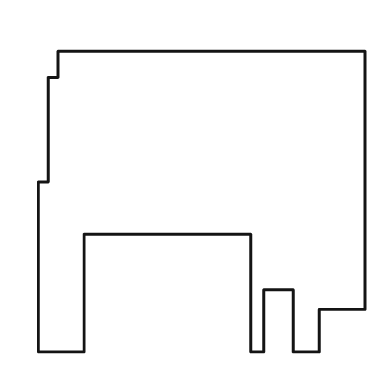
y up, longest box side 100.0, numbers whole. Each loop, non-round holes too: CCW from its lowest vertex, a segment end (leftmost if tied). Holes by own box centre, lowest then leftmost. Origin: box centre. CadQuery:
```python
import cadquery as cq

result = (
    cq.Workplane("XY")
    .moveTo(-50.0, -46.0)
    .lineTo(-36.0, -46.0)
    .lineTo(-36.0, -10.0)
    .lineTo(15.0, -10.0)
    .lineTo(15.0, -46.0)
    .lineTo(19.0, -46.0)
    .lineTo(19.0, -27.0)
    .lineTo(28.0, -27.0)
    .lineTo(28.0, -46.0)
    .lineTo(36.0, -46.0)
    .lineTo(36.0, -33.0)
    .lineTo(50.0, -33.0)
    .lineTo(50.0, 46.0)
    .lineTo(-44.0, 46.0)
    .lineTo(-44.0, 38.0)
    .lineTo(-47.0, 38.0)
    .lineTo(-47.0, 6.0)
    .lineTo(-50.0, 6.0)
    .close()
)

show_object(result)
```